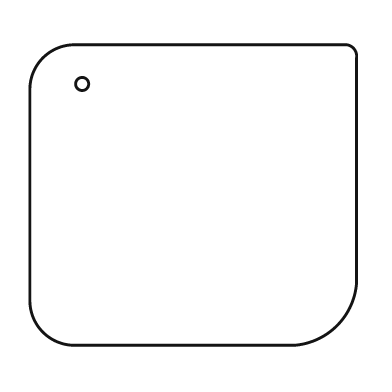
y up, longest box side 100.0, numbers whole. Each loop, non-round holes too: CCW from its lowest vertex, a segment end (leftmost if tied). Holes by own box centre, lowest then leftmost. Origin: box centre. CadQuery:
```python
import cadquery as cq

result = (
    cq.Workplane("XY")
    .moveTo(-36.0, -46.0)
    .lineTo(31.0, -46.0)
    .threePointArc((44.0, -40.0), (50.0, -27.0))
    .lineTo(50.0, 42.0)
    .threePointArc((49.0, 45.0), (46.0, 46.0))
    .lineTo(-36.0, 46.0)
    .threePointArc((-46.0, 42.0), (-50.0, 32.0))
    .lineTo(-50.0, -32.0)
    .threePointArc((-46.0, -42.0), (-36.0, -46.0))
    .close()
    .moveTo(-34.0, 34.0)
    .circle(2.0)
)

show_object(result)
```